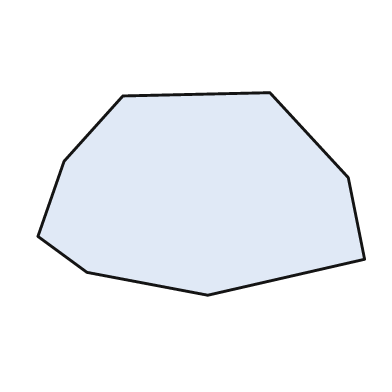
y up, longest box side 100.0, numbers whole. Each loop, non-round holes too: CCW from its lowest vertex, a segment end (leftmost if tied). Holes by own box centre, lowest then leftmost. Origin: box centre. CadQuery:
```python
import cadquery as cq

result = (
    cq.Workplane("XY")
    .moveTo(2.0, -31.0)
    .lineTo(50.0, -20.0)
    .lineTo(45.0, 5.0)
    .lineTo(21.0, 31.0)
    .lineTo(-24.0, 30.0)
    .lineTo(-42.0, 10.0)
    .lineTo(-50.0, -13.0)
    .lineTo(-35.0, -24.0)
    .close()
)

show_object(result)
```